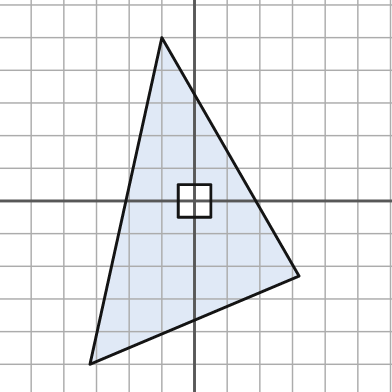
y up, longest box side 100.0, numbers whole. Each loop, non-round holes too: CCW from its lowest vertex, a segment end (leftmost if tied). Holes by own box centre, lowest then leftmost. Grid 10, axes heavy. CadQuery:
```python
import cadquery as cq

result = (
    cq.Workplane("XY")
    .moveTo(-32.0, -50.0)
    .lineTo(32.0, -23.0)
    .lineTo(-10.0, 50.0)
    .close()
    .moveTo(-5.0, -5.0)
    .lineTo(5.0, -5.0)
    .lineTo(5.0, 5.0)
    .lineTo(-5.0, 5.0)
    .close()
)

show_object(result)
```